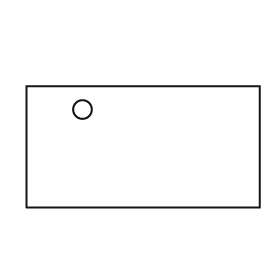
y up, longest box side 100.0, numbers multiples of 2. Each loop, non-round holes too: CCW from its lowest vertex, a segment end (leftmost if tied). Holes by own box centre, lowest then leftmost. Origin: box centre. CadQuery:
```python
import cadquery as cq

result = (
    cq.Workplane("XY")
    .moveTo(-50.0, -26.0)
    .lineTo(50.0, -26.0)
    .lineTo(50.0, 26.0)
    .lineTo(-50.0, 26.0)
    .close()
    .moveTo(-26.0, 16.0)
    .circle(4.0)
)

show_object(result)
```